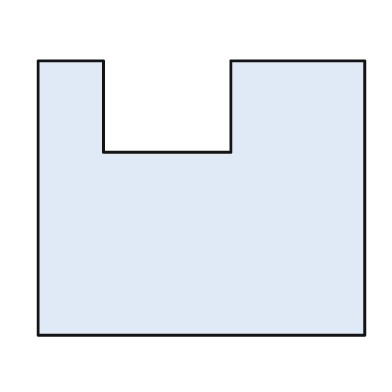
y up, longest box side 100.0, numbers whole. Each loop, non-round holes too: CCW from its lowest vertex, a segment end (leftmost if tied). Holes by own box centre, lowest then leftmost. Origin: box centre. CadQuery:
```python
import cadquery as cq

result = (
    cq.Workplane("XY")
    .moveTo(-50.0, -42.0)
    .lineTo(50.0, -42.0)
    .lineTo(50.0, 42.0)
    .lineTo(9.0, 42.0)
    .lineTo(9.0, 14.0)
    .lineTo(-30.0, 14.0)
    .lineTo(-30.0, 42.0)
    .lineTo(-50.0, 42.0)
    .close()
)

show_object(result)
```